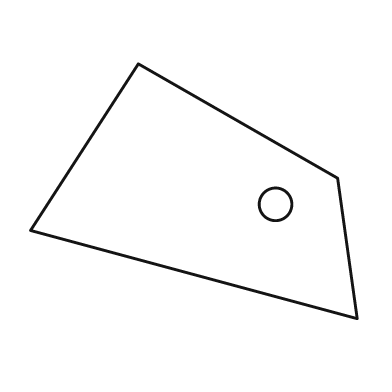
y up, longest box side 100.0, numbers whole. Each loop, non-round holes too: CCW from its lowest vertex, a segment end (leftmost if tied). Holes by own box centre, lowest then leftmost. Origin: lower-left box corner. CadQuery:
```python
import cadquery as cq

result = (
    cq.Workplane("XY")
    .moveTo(100.0, 0.0)
    .lineTo(94.0, 43.0)
    .lineTo(33.0, 78.0)
    .lineTo(0.0, 27.0)
    .close()
    .moveTo(75.0, 35.0)
    .circle(5.0)
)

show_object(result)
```